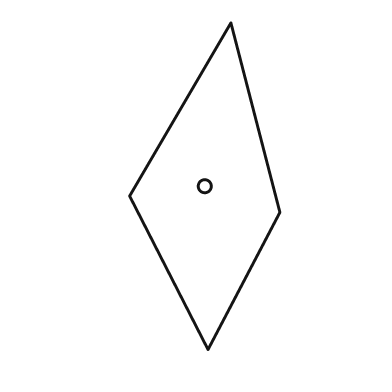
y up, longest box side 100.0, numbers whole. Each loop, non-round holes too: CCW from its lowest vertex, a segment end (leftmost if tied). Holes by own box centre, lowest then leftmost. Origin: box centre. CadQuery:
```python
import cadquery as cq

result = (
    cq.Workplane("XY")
    .moveTo(1.0, -50.0)
    .lineTo(23.0, -8.0)
    .lineTo(8.0, 50.0)
    .lineTo(-23.0, -3.0)
    .close()
    .moveTo(0.0, 0.0)
    .circle(2.0)
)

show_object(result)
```